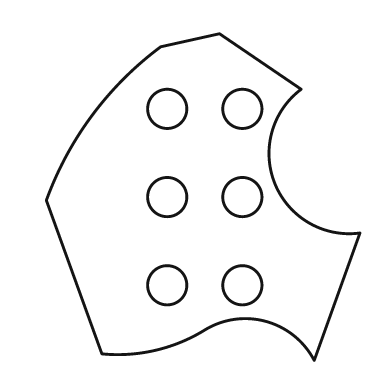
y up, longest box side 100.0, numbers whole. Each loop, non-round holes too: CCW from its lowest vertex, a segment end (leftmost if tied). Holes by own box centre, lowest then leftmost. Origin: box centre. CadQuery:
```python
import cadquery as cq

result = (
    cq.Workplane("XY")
    .moveTo(34.0, -50.0)
    .lineTo(48.0, -11.0)
    .threePointArc((22.0, 4.0), (30.0, 33.0))
    .lineTo(5.0, 50.0)
    .lineTo(-13.0, 46.0)
    .threePointArc((-34.0, 25.0), (-48.0, -1.0))
    .lineTo(-31.0, -48.0)
    .threePointArc((-15.0, -47.0), (0.0, -41.0))
    .threePointArc((19.0, -38.0), (34.0, -50.0))
    .close()
    .moveTo(-11.0, -27.0)
    .circle(6.0)
    .moveTo(12.0, -27.0)
    .circle(6.0)
    .moveTo(-11.0, 0.0)
    .circle(6.0)
    .moveTo(12.0, 0.0)
    .circle(6.0)
    .moveTo(-11.0, 27.0)
    .circle(6.0)
    .moveTo(12.0, 27.0)
    .circle(6.0)
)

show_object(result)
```